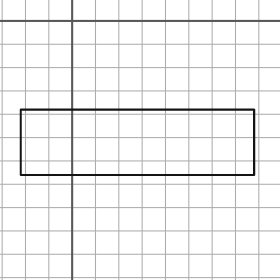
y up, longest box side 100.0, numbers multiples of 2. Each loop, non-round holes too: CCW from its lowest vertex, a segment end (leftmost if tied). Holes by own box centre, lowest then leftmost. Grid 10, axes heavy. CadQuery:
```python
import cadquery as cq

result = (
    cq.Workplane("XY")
    .moveTo(-22.0, -66.0)
    .lineTo(78.0, -66.0)
    .lineTo(78.0, -38.0)
    .lineTo(-22.0, -38.0)
    .close()
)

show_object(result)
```